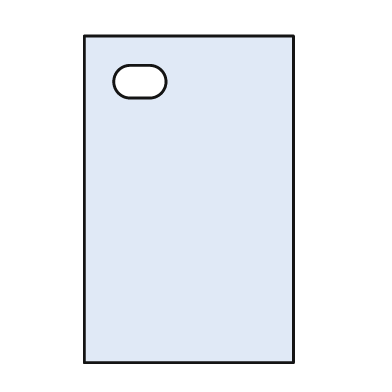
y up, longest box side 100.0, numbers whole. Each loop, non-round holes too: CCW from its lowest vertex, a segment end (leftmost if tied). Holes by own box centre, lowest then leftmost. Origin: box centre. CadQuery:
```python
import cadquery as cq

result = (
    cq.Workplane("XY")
    .moveTo(-32.0, -50.0)
    .lineTo(32.0, -50.0)
    .lineTo(32.0, 50.0)
    .lineTo(-32.0, 50.0)
    .close()
    .moveTo(-18.0, 31.0)
    .lineTo(-12.0, 31.0)
    .threePointArc((-7.0, 36.0), (-12.0, 41.0))
    .lineTo(-18.0, 41.0)
    .threePointArc((-23.0, 36.0), (-18.0, 31.0))
    .close()
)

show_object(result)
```